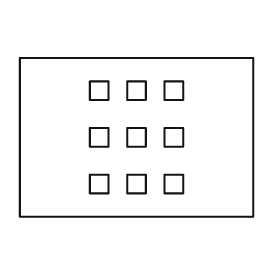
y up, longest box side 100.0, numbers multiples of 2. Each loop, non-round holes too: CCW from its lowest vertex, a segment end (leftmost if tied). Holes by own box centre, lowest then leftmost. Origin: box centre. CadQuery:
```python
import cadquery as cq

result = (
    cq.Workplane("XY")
    .moveTo(-50.0, -34.0)
    .lineTo(50.0, -34.0)
    .lineTo(50.0, 34.0)
    .lineTo(-50.0, 34.0)
    .close()
    .moveTo(-20.0, -24.0)
    .lineTo(-12.0, -24.0)
    .lineTo(-12.0, -16.0)
    .lineTo(-20.0, -16.0)
    .close()
    .moveTo(-4.0, -24.0)
    .lineTo(4.0, -24.0)
    .lineTo(4.0, -16.0)
    .lineTo(-4.0, -16.0)
    .close()
    .moveTo(12.0, -24.0)
    .lineTo(20.0, -24.0)
    .lineTo(20.0, -16.0)
    .lineTo(12.0, -16.0)
    .close()
    .moveTo(-20.0, -4.0)
    .lineTo(-12.0, -4.0)
    .lineTo(-12.0, 4.0)
    .lineTo(-20.0, 4.0)
    .close()
    .moveTo(-4.0, -4.0)
    .lineTo(4.0, -4.0)
    .lineTo(4.0, 4.0)
    .lineTo(-4.0, 4.0)
    .close()
    .moveTo(12.0, -4.0)
    .lineTo(20.0, -4.0)
    .lineTo(20.0, 4.0)
    .lineTo(12.0, 4.0)
    .close()
    .moveTo(-20.0, 16.0)
    .lineTo(-12.0, 16.0)
    .lineTo(-12.0, 24.0)
    .lineTo(-20.0, 24.0)
    .close()
    .moveTo(-4.0, 16.0)
    .lineTo(4.0, 16.0)
    .lineTo(4.0, 24.0)
    .lineTo(-4.0, 24.0)
    .close()
    .moveTo(12.0, 16.0)
    .lineTo(20.0, 16.0)
    .lineTo(20.0, 24.0)
    .lineTo(12.0, 24.0)
    .close()
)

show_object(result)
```